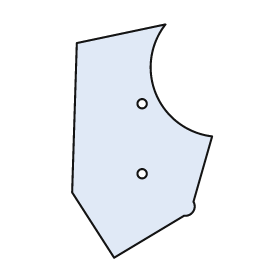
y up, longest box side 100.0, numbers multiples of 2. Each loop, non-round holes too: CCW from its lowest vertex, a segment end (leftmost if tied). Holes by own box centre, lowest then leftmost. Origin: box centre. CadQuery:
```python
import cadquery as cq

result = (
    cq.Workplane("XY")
    .moveTo(-12.0, -50.0)
    .lineTo(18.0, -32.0)
    .threePointArc((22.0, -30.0), (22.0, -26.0))
    .lineTo(30.0, 2.0)
    .threePointArc((6.0, 20.0), (10.0, 50.0))
    .lineTo(-28.0, 42.0)
    .lineTo(-30.0, -22.0)
    .close()
    .moveTo(0.0, -14.0)
    .circle(2.0)
    .moveTo(0.0, 16.0)
    .circle(2.0)
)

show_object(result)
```